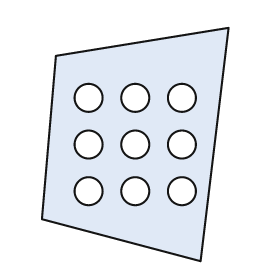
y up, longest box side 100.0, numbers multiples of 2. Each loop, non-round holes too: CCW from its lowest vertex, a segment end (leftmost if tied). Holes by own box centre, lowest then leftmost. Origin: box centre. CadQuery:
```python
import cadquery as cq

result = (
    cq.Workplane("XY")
    .moveTo(28.0, -50.0)
    .lineTo(40.0, 50.0)
    .lineTo(-34.0, 38.0)
    .lineTo(-40.0, -32.0)
    .close()
    .moveTo(-20.0, -20.0)
    .circle(6.0)
    .moveTo(0.0, -20.0)
    .circle(6.0)
    .moveTo(20.0, -20.0)
    .circle(6.0)
    .moveTo(-20.0, 0.0)
    .circle(6.0)
    .moveTo(0.0, 0.0)
    .circle(6.0)
    .moveTo(20.0, 0.0)
    .circle(6.0)
    .moveTo(-20.0, 20.0)
    .circle(6.0)
    .moveTo(0.0, 20.0)
    .circle(6.0)
    .moveTo(20.0, 20.0)
    .circle(6.0)
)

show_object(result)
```